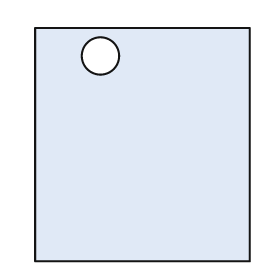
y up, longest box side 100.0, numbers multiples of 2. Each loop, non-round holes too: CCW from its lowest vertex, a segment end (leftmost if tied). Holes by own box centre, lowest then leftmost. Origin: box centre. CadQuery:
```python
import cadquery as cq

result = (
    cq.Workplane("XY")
    .moveTo(-46.0, -50.0)
    .lineTo(46.0, -50.0)
    .lineTo(46.0, 50.0)
    .lineTo(-46.0, 50.0)
    .close()
    .moveTo(-18.0, 38.0)
    .circle(8.0)
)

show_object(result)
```